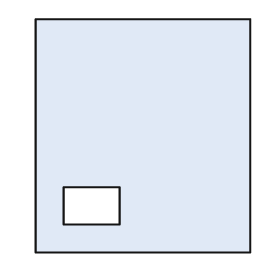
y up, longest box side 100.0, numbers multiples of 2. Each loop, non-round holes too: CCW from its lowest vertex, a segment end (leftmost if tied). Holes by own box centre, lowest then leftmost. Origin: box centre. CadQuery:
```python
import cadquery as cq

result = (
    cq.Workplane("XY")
    .moveTo(-46.0, -50.0)
    .lineTo(46.0, -50.0)
    .lineTo(46.0, 50.0)
    .lineTo(-46.0, 50.0)
    .close()
    .moveTo(-34.0, -38.0)
    .lineTo(-10.0, -38.0)
    .lineTo(-10.0, -22.0)
    .lineTo(-34.0, -22.0)
    .close()
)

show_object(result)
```